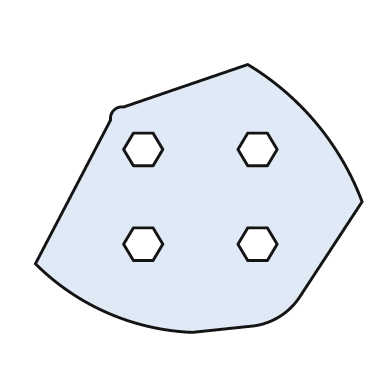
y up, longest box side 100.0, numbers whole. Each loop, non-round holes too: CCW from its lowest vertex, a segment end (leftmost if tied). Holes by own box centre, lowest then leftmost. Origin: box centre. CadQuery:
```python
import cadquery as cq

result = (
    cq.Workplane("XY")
    .moveTo(-2.0, -41.0)
    .lineTo(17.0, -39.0)
    .threePointArc((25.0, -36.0), (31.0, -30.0))
    .lineTo(50.0, -1.0)
    .threePointArc((36.0, 23.0), (15.0, 41.0))
    .lineTo(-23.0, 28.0)
    .threePointArc((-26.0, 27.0), (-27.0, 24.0))
    .lineTo(-50.0, -20.0)
    .threePointArc((-28.0, -35.0), (-2.0, -41.0))
    .close()
    .moveTo(-20.0, -19.0)
    .lineTo(-14.0, -19.0)
    .lineTo(-11.0, -14.0)
    .lineTo(-14.0, -9.0)
    .lineTo(-20.0, -9.0)
    .lineTo(-23.0, -14.0)
    .close()
    .moveTo(15.0, -19.0)
    .lineTo(21.0, -19.0)
    .lineTo(24.0, -14.0)
    .lineTo(21.0, -9.0)
    .lineTo(15.0, -9.0)
    .lineTo(12.0, -14.0)
    .close()
    .moveTo(-20.0, 10.0)
    .lineTo(-14.0, 10.0)
    .lineTo(-11.0, 15.0)
    .lineTo(-14.0, 20.0)
    .lineTo(-20.0, 20.0)
    .lineTo(-23.0, 15.0)
    .close()
    .moveTo(15.0, 10.0)
    .lineTo(21.0, 10.0)
    .lineTo(24.0, 15.0)
    .lineTo(21.0, 20.0)
    .lineTo(15.0, 20.0)
    .lineTo(12.0, 15.0)
    .close()
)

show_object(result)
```